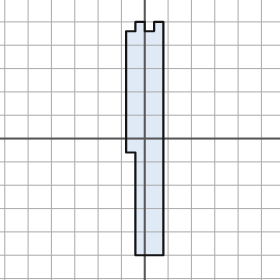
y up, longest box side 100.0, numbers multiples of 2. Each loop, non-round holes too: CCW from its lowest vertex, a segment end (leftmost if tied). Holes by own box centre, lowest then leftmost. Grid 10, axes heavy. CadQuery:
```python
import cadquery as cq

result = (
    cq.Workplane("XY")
    .moveTo(-4.0, -50.0)
    .lineTo(8.0, -50.0)
    .lineTo(8.0, 50.0)
    .lineTo(4.0, 50.0)
    .lineTo(4.0, 46.0)
    .lineTo(0.0, 46.0)
    .lineTo(0.0, 50.0)
    .lineTo(-4.0, 50.0)
    .lineTo(-4.0, 46.0)
    .lineTo(-8.0, 46.0)
    .lineTo(-8.0, -6.0)
    .lineTo(-4.0, -6.0)
    .close()
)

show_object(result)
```